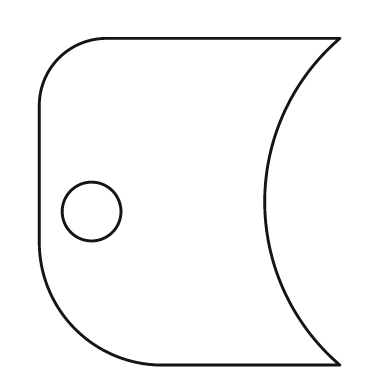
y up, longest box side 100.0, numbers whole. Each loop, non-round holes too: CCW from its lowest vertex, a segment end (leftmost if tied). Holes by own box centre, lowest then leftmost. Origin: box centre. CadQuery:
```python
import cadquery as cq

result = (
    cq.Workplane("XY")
    .moveTo(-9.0, -50.0)
    .lineTo(46.0, -50.0)
    .threePointArc((23.0, 0.0), (46.0, 50.0))
    .lineTo(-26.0, 50.0)
    .threePointArc((-40.0, 44.0), (-46.0, 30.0))
    .lineTo(-46.0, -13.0)
    .threePointArc((-35.0, -39.0), (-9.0, -50.0))
    .close()
    .moveTo(-30.0, -3.0)
    .circle(9.0)
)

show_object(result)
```